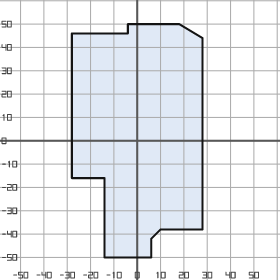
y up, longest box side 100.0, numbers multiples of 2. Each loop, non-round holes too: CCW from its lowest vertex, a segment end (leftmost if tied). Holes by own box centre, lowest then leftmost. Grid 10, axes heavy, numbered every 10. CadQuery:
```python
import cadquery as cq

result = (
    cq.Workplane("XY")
    .moveTo(-14.0, -50.0)
    .lineTo(6.0, -50.0)
    .lineTo(6.0, -42.0)
    .lineTo(10.0, -38.0)
    .lineTo(28.0, -38.0)
    .lineTo(28.0, 44.0)
    .lineTo(18.0, 50.0)
    .lineTo(-4.0, 50.0)
    .lineTo(-4.0, 46.0)
    .lineTo(-28.0, 46.0)
    .lineTo(-28.0, -16.0)
    .lineTo(-14.0, -16.0)
    .close()
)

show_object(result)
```